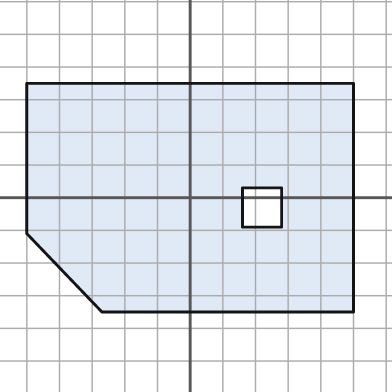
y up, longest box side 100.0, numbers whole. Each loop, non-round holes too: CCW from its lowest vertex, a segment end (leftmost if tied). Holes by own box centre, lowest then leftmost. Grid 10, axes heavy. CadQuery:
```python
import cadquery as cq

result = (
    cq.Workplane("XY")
    .moveTo(-27.0, -35.0)
    .lineTo(50.0, -35.0)
    .lineTo(50.0, 35.0)
    .lineTo(-50.0, 35.0)
    .lineTo(-50.0, -11.0)
    .close()
    .moveTo(16.0, -9.0)
    .lineTo(28.0, -9.0)
    .lineTo(28.0, 3.0)
    .lineTo(16.0, 3.0)
    .close()
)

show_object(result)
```